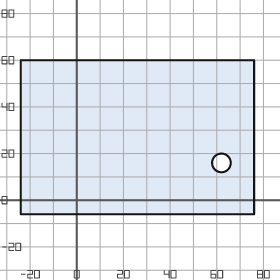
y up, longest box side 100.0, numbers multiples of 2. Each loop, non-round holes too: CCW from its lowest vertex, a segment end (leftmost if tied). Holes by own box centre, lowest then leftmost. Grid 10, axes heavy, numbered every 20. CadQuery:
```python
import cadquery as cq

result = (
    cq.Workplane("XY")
    .moveTo(-24.0, -6.0)
    .lineTo(76.0, -6.0)
    .lineTo(76.0, 60.0)
    .lineTo(-24.0, 60.0)
    .close()
    .moveTo(62.0, 16.0)
    .circle(4.0)
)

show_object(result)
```